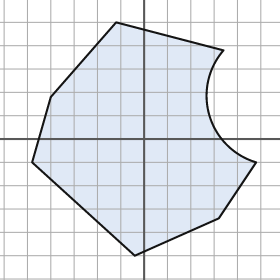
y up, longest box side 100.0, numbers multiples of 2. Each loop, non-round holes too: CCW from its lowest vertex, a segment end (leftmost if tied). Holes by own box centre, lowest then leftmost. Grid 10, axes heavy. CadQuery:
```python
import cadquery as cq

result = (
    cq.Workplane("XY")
    .moveTo(-4.0, -50.0)
    .lineTo(32.0, -34.0)
    .lineTo(48.0, -10.0)
    .threePointArc((28.0, 10.0), (34.0, 38.0))
    .lineTo(-12.0, 50.0)
    .lineTo(-40.0, 18.0)
    .lineTo(-48.0, -10.0)
    .close()
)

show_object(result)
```